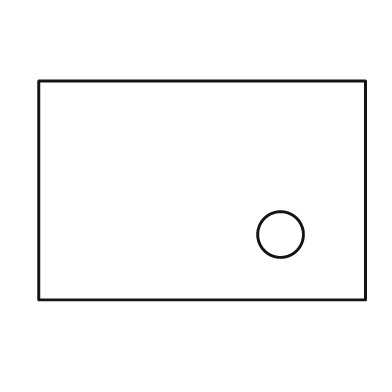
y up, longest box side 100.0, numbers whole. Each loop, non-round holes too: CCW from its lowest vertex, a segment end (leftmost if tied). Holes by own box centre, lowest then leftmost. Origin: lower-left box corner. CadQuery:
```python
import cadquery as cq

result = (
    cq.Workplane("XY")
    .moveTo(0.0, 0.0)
    .lineTo(100.0, 0.0)
    .lineTo(100.0, 67.0)
    .lineTo(0.0, 67.0)
    .close()
    .moveTo(74.0, 20.0)
    .circle(7.0)
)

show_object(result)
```